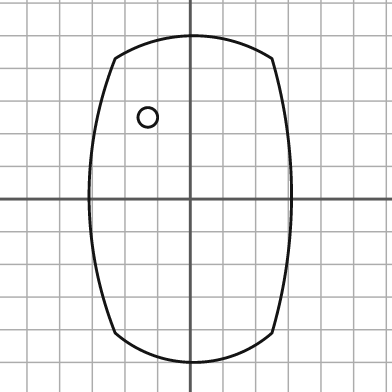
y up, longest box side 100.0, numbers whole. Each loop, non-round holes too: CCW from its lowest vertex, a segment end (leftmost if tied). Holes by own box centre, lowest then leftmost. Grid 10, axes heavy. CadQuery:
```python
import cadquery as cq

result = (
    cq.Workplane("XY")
    .moveTo(-23.0, -41.0)
    .threePointArc((1.0, -50.0), (25.0, -41.0))
    .threePointArc((31.0, 1.0), (25.0, 43.0))
    .threePointArc((1.0, 50.0), (-23.0, 43.0))
    .threePointArc((-31.0, 1.0), (-23.0, -41.0))
    .close()
    .moveTo(-13.0, 25.0)
    .circle(3.0)
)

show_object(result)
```